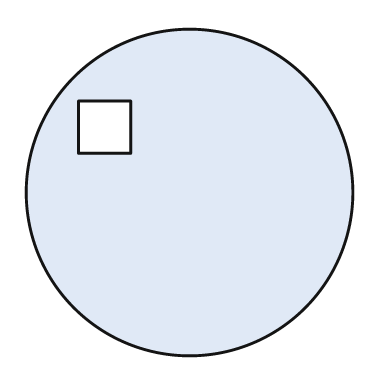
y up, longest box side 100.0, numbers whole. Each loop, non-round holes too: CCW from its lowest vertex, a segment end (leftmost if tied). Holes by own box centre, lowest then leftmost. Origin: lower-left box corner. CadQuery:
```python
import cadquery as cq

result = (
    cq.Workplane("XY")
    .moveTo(50.0, 50.0)
    .circle(50.0)
    .moveTo(16.0, 62.0)
    .lineTo(32.0, 62.0)
    .lineTo(32.0, 78.0)
    .lineTo(16.0, 78.0)
    .close()
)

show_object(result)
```